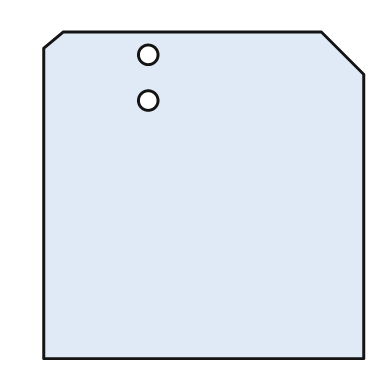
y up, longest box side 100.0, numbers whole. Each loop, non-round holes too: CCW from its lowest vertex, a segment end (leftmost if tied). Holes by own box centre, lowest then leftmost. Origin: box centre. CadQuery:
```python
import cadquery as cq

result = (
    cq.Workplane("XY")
    .moveTo(-49.0, -50.0)
    .lineTo(49.0, -50.0)
    .lineTo(49.0, 37.0)
    .lineTo(36.0, 50.0)
    .lineTo(-43.0, 50.0)
    .lineTo(-49.0, 45.0)
    .close()
    .moveTo(-17.0, 29.0)
    .circle(3.0)
    .moveTo(-17.0, 43.0)
    .circle(3.0)
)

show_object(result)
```